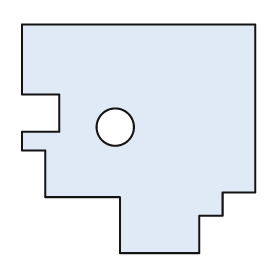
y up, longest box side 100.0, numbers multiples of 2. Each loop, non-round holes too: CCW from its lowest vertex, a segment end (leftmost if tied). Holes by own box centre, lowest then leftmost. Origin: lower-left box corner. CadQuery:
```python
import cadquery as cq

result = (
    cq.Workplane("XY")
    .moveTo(42.0, 0.0)
    .lineTo(76.0, 0.0)
    .lineTo(76.0, 16.0)
    .lineTo(86.0, 16.0)
    .lineTo(86.0, 26.0)
    .lineTo(100.0, 26.0)
    .lineTo(100.0, 98.0)
    .lineTo(0.0, 98.0)
    .lineTo(0.0, 68.0)
    .lineTo(16.0, 68.0)
    .lineTo(16.0, 52.0)
    .lineTo(0.0, 52.0)
    .lineTo(0.0, 44.0)
    .lineTo(10.0, 44.0)
    .lineTo(10.0, 24.0)
    .lineTo(42.0, 24.0)
    .close()
    .moveTo(40.0, 54.0)
    .circle(8.0)
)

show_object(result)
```